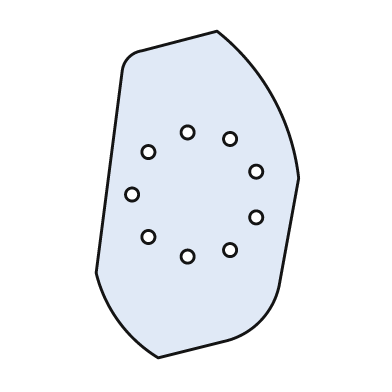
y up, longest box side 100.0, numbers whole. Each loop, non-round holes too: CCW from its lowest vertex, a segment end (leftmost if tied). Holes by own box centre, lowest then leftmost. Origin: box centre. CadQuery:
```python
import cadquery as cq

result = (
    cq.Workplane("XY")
    .moveTo(-12.0, -50.0)
    .lineTo(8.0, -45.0)
    .threePointArc((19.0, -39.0), (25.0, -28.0))
    .lineTo(31.0, 5.0)
    .threePointArc((23.0, 30.0), (6.0, 50.0))
    .lineTo(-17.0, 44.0)
    .threePointArc((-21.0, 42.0), (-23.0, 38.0))
    .lineTo(-31.0, -24.0)
    .threePointArc((-24.0, -39.0), (-12.0, -50.0))
    .close()
    .moveTo(-3.0, -19.0)
    .circle(2.0)
    .moveTo(10.0, -17.0)
    .circle(2.0)
    .moveTo(-15.0, -13.0)
    .circle(2.0)
    .moveTo(18.0, -7.0)
    .circle(2.0)
    .moveTo(-20.0, 0.0)
    .circle(2.0)
    .moveTo(18.0, 7.0)
    .circle(2.0)
    .moveTo(-15.0, 13.0)
    .circle(2.0)
    .moveTo(10.0, 17.0)
    .circle(2.0)
    .moveTo(-3.0, 19.0)
    .circle(2.0)
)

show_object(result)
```